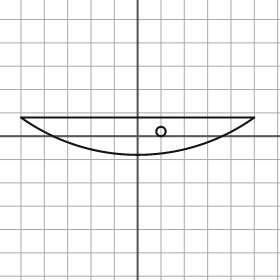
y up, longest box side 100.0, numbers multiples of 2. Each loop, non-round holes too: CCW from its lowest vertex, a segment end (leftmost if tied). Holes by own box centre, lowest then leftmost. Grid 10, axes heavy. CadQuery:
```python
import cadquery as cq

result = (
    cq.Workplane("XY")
    .moveTo(-50.0, 8.0)
    .threePointArc((0.0, -8.0), (50.0, 8.0))
    .close()
    .moveTo(10.0, 2.0)
    .circle(2.0)
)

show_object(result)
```